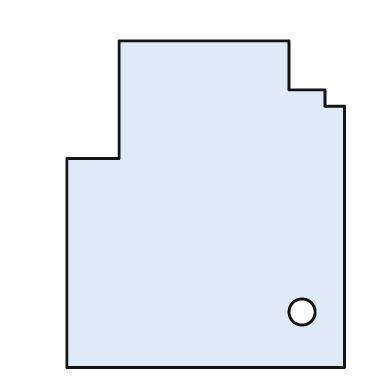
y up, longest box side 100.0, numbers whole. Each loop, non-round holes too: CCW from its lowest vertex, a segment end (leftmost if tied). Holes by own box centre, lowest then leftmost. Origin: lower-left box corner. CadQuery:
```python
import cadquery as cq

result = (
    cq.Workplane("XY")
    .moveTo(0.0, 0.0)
    .lineTo(85.0, 0.0)
    .lineTo(85.0, 80.0)
    .lineTo(79.0, 80.0)
    .lineTo(79.0, 85.0)
    .lineTo(68.0, 85.0)
    .lineTo(68.0, 100.0)
    .lineTo(16.0, 100.0)
    .lineTo(16.0, 64.0)
    .lineTo(0.0, 64.0)
    .close()
    .moveTo(72.0, 17.0)
    .circle(4.0)
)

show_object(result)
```